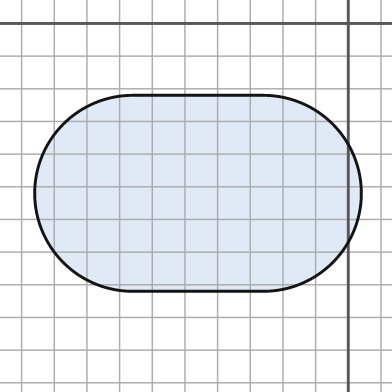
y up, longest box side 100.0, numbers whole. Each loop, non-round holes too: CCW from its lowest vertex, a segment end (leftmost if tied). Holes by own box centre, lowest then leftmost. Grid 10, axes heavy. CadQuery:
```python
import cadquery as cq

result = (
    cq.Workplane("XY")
    .moveTo(-66.0, -82.0)
    .lineTo(-26.0, -82.0)
    .threePointArc((4.0, -52.0), (-26.0, -22.0))
    .lineTo(-66.0, -22.0)
    .threePointArc((-96.0, -52.0), (-66.0, -82.0))
    .close()
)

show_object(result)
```